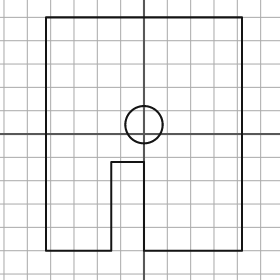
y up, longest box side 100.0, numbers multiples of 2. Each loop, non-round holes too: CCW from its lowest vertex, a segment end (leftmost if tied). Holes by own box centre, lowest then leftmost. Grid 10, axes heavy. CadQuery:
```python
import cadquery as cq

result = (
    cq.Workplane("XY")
    .moveTo(-42.0, -50.0)
    .lineTo(-14.0, -50.0)
    .lineTo(-14.0, -12.0)
    .lineTo(0.0, -12.0)
    .lineTo(0.0, -50.0)
    .lineTo(42.0, -50.0)
    .lineTo(42.0, 50.0)
    .lineTo(-42.0, 50.0)
    .close()
    .moveTo(0.0, 4.0)
    .circle(8.0)
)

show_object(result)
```